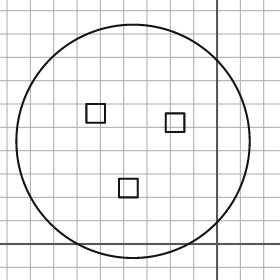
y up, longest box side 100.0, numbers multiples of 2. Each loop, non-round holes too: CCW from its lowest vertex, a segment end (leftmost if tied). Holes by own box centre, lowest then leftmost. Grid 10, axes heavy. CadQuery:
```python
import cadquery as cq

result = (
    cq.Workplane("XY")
    .moveTo(-36.0, 44.0)
    .circle(50.0)
    .moveTo(-42.0, 20.0)
    .lineTo(-34.0, 20.0)
    .lineTo(-34.0, 28.0)
    .lineTo(-42.0, 28.0)
    .close()
    .moveTo(-22.0, 48.0)
    .lineTo(-14.0, 48.0)
    .lineTo(-14.0, 56.0)
    .lineTo(-22.0, 56.0)
    .close()
    .moveTo(-56.0, 52.0)
    .lineTo(-48.0, 52.0)
    .lineTo(-48.0, 60.0)
    .lineTo(-56.0, 60.0)
    .close()
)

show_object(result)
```